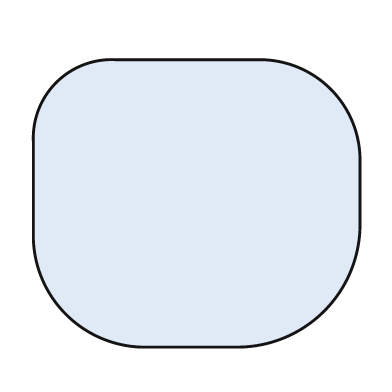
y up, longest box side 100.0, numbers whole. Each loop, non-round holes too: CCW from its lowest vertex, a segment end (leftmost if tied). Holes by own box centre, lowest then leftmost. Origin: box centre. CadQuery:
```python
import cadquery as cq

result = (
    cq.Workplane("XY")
    .moveTo(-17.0, -44.0)
    .lineTo(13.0, -44.0)
    .threePointArc((39.0, -33.0), (50.0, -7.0))
    .lineTo(50.0, 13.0)
    .threePointArc((41.0, 35.0), (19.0, 44.0))
    .lineTo(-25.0, 44.0)
    .threePointArc((-43.0, 37.0), (-50.0, 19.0))
    .lineTo(-50.0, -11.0)
    .threePointArc((-40.0, -34.0), (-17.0, -44.0))
    .close()
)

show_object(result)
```